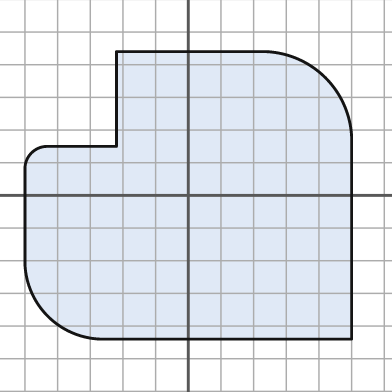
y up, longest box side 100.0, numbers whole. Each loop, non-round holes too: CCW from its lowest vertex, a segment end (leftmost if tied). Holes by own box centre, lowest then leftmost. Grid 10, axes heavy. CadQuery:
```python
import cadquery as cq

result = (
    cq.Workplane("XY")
    .moveTo(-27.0, -44.0)
    .lineTo(50.0, -44.0)
    .lineTo(50.0, 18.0)
    .threePointArc((42.0, 36.0), (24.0, 44.0))
    .lineTo(-22.0, 44.0)
    .lineTo(-22.0, 15.0)
    .lineTo(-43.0, 15.0)
    .threePointArc((-48.0, 13.0), (-50.0, 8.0))
    .lineTo(-50.0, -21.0)
    .threePointArc((-43.0, -37.0), (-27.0, -44.0))
    .close()
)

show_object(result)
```